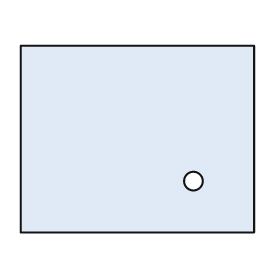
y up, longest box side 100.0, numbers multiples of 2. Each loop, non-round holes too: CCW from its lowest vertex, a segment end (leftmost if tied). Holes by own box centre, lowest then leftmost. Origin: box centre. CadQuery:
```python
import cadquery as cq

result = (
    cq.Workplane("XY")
    .moveTo(-50.0, -40.0)
    .lineTo(50.0, -40.0)
    .lineTo(50.0, 40.0)
    .lineTo(-50.0, 40.0)
    .close()
    .moveTo(24.0, -18.0)
    .circle(4.0)
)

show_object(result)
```